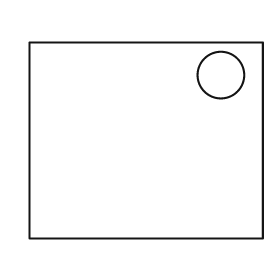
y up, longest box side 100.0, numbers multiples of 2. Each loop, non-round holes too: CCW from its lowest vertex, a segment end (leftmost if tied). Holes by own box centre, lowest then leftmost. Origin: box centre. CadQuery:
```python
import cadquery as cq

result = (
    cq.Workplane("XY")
    .moveTo(-50.0, -42.0)
    .lineTo(50.0, -42.0)
    .lineTo(50.0, 42.0)
    .lineTo(-50.0, 42.0)
    .close()
    .moveTo(32.0, 28.0)
    .circle(10.0)
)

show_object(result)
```